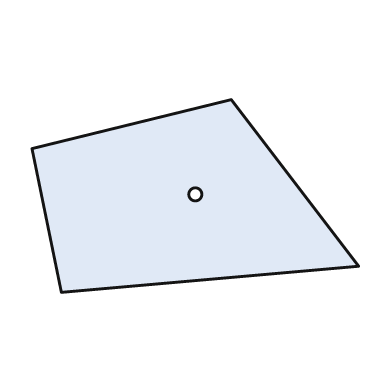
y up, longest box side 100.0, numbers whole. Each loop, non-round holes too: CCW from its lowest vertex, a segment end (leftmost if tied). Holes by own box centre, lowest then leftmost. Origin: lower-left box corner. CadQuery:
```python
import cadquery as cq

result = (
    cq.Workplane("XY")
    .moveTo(9.0, 0.0)
    .lineTo(100.0, 8.0)
    .lineTo(61.0, 59.0)
    .lineTo(0.0, 44.0)
    .close()
    .moveTo(50.0, 30.0)
    .circle(2.0)
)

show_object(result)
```